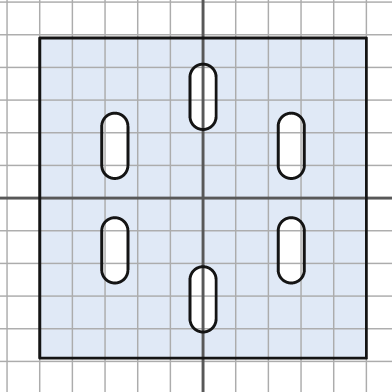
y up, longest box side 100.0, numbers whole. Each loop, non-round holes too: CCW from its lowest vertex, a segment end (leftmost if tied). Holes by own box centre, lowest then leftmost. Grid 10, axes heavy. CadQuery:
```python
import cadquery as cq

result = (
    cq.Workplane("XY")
    .moveTo(-50.0, -49.0)
    .lineTo(50.0, -49.0)
    .lineTo(50.0, 49.0)
    .lineTo(-50.0, 49.0)
    .close()
    .moveTo(-4.0, -37.0)
    .threePointArc((0.0, -41.0), (4.0, -37.0))
    .lineTo(4.0, -25.0)
    .threePointArc((0.0, -21.0), (-4.0, -25.0))
    .close()
    .moveTo(-31.0, -22.0)
    .threePointArc((-27.0, -26.0), (-23.0, -22.0))
    .lineTo(-23.0, -10.0)
    .threePointArc((-27.0, -6.0), (-31.0, -10.0))
    .close()
    .moveTo(23.0, -22.0)
    .threePointArc((27.0, -26.0), (31.0, -22.0))
    .lineTo(31.0, -10.0)
    .threePointArc((27.0, -6.0), (23.0, -10.0))
    .close()
    .moveTo(-31.0, 10.0)
    .threePointArc((-27.0, 6.0), (-23.0, 10.0))
    .lineTo(-23.0, 22.0)
    .threePointArc((-27.0, 26.0), (-31.0, 22.0))
    .close()
    .moveTo(23.0, 10.0)
    .threePointArc((27.0, 6.0), (31.0, 10.0))
    .lineTo(31.0, 22.0)
    .threePointArc((27.0, 26.0), (23.0, 22.0))
    .close()
    .moveTo(-4.0, 25.0)
    .threePointArc((0.0, 21.0), (4.0, 25.0))
    .lineTo(4.0, 37.0)
    .threePointArc((0.0, 41.0), (-4.0, 37.0))
    .close()
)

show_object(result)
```